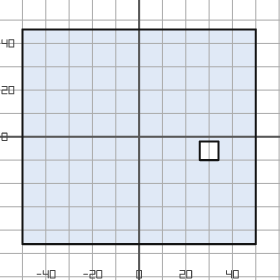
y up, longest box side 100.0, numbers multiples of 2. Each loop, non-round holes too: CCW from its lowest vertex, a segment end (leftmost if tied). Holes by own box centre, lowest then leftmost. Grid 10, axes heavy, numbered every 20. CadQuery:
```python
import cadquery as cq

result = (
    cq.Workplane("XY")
    .moveTo(-50.0, -46.0)
    .lineTo(50.0, -46.0)
    .lineTo(50.0, 46.0)
    .lineTo(-50.0, 46.0)
    .close()
    .moveTo(26.0, -10.0)
    .lineTo(34.0, -10.0)
    .lineTo(34.0, -2.0)
    .lineTo(26.0, -2.0)
    .close()
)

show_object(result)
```